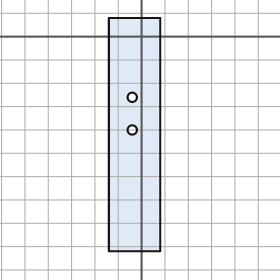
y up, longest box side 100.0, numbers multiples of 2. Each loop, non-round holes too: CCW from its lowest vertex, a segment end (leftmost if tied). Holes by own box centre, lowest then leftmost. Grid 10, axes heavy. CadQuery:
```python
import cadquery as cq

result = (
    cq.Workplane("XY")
    .moveTo(-14.0, -92.0)
    .lineTo(8.0, -92.0)
    .lineTo(8.0, 8.0)
    .lineTo(-14.0, 8.0)
    .close()
    .moveTo(-4.0, -40.0)
    .circle(2.0)
    .moveTo(-4.0, -26.0)
    .circle(2.0)
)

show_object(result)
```